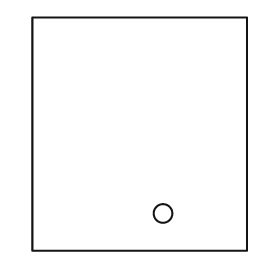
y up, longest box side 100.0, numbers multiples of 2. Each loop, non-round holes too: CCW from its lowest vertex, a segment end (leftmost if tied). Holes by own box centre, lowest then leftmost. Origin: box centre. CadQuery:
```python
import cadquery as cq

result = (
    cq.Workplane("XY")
    .moveTo(-46.0, -50.0)
    .lineTo(46.0, -50.0)
    .lineTo(46.0, 50.0)
    .lineTo(-46.0, 50.0)
    .close()
    .moveTo(10.0, -34.0)
    .circle(4.0)
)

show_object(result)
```